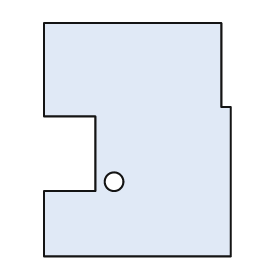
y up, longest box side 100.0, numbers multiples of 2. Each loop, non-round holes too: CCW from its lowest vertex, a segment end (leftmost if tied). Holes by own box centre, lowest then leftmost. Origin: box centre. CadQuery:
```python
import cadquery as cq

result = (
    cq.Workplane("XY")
    .moveTo(-40.0, -50.0)
    .lineTo(40.0, -50.0)
    .lineTo(40.0, 14.0)
    .lineTo(36.0, 14.0)
    .lineTo(36.0, 50.0)
    .lineTo(-40.0, 50.0)
    .lineTo(-40.0, 10.0)
    .lineTo(-18.0, 10.0)
    .lineTo(-18.0, -22.0)
    .lineTo(-40.0, -22.0)
    .close()
    .moveTo(-10.0, -18.0)
    .circle(4.0)
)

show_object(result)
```